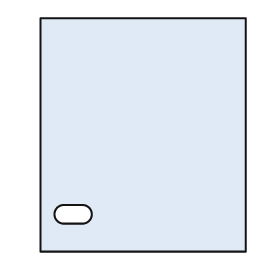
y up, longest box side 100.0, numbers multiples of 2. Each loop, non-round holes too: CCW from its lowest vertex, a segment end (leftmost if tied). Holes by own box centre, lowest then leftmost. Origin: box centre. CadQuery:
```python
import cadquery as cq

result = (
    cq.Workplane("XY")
    .moveTo(-44.0, -50.0)
    .lineTo(44.0, -50.0)
    .lineTo(44.0, 50.0)
    .lineTo(-44.0, 50.0)
    .close()
    .moveTo(-34.0, -38.0)
    .lineTo(-26.0, -38.0)
    .threePointArc((-22.0, -34.0), (-26.0, -30.0))
    .lineTo(-34.0, -30.0)
    .threePointArc((-38.0, -34.0), (-34.0, -38.0))
    .close()
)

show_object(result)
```